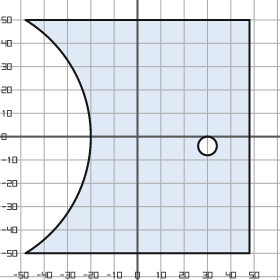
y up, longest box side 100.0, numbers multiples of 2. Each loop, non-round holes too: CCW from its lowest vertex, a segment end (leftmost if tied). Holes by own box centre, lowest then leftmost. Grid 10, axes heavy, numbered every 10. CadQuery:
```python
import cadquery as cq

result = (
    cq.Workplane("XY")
    .moveTo(-48.0, -50.0)
    .lineTo(48.0, -50.0)
    .lineTo(48.0, 50.0)
    .lineTo(-48.0, 50.0)
    .threePointArc((-20.0, 0.0), (-48.0, -50.0))
    .close()
    .moveTo(30.0, -4.0)
    .circle(4.0)
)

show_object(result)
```